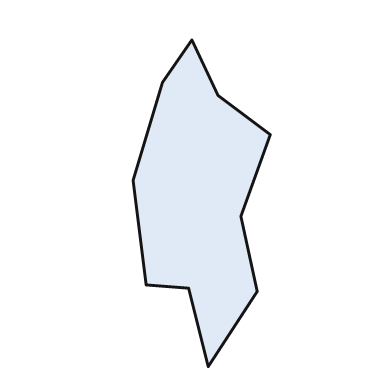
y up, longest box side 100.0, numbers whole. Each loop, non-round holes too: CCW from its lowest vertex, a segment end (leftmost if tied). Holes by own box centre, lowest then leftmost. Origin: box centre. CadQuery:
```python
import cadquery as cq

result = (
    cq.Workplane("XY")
    .moveTo(2.0, -50.0)
    .lineTo(17.0, -27.0)
    .lineTo(12.0, -4.0)
    .lineTo(21.0, 21.0)
    .lineTo(5.0, 33.0)
    .lineTo(-3.0, 50.0)
    .lineTo(-12.0, 37.0)
    .lineTo(-21.0, 7.0)
    .lineTo(-17.0, -25.0)
    .lineTo(-4.0, -26.0)
    .close()
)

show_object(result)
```